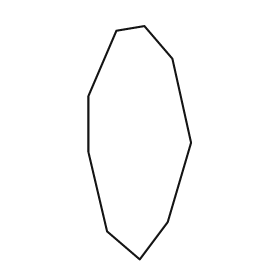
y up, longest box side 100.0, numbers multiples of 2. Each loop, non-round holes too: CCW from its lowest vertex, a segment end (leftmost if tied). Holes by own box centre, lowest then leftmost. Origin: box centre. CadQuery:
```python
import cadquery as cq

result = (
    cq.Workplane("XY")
    .moveTo(0.0, -50.0)
    .lineTo(12.0, -34.0)
    .lineTo(22.0, 0.0)
    .lineTo(14.0, 36.0)
    .lineTo(2.0, 50.0)
    .lineTo(-10.0, 48.0)
    .lineTo(-22.0, 20.0)
    .lineTo(-22.0, -4.0)
    .lineTo(-14.0, -38.0)
    .close()
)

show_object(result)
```